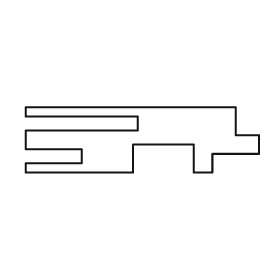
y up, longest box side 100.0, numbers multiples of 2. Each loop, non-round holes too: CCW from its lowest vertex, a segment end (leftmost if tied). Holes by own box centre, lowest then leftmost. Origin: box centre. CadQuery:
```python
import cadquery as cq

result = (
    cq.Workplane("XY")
    .moveTo(-50.0, -14.0)
    .lineTo(-4.0, -14.0)
    .lineTo(-4.0, -2.0)
    .lineTo(22.0, -2.0)
    .lineTo(22.0, -14.0)
    .lineTo(30.0, -14.0)
    .lineTo(30.0, -6.0)
    .lineTo(50.0, -6.0)
    .lineTo(50.0, 2.0)
    .lineTo(40.0, 2.0)
    .lineTo(40.0, 14.0)
    .lineTo(-50.0, 14.0)
    .lineTo(-50.0, 10.0)
    .lineTo(-2.0, 10.0)
    .lineTo(-2.0, 4.0)
    .lineTo(-50.0, 4.0)
    .lineTo(-50.0, -4.0)
    .lineTo(-26.0, -4.0)
    .lineTo(-26.0, -10.0)
    .lineTo(-50.0, -10.0)
    .close()
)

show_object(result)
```